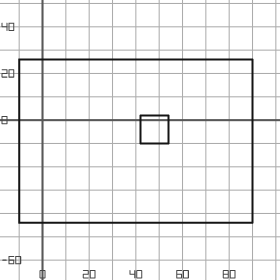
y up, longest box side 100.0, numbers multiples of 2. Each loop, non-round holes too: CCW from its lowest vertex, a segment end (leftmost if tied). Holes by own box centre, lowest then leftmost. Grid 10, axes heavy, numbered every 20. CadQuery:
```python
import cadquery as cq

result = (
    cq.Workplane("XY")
    .moveTo(-10.0, -44.0)
    .lineTo(90.0, -44.0)
    .lineTo(90.0, 26.0)
    .lineTo(-10.0, 26.0)
    .close()
    .moveTo(42.0, -10.0)
    .lineTo(54.0, -10.0)
    .lineTo(54.0, 2.0)
    .lineTo(42.0, 2.0)
    .close()
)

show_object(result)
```